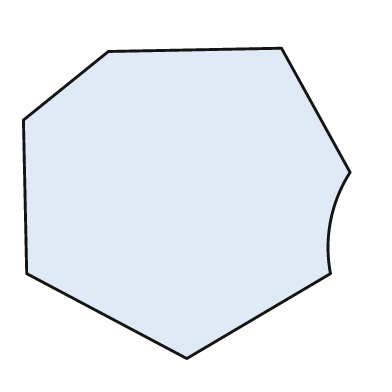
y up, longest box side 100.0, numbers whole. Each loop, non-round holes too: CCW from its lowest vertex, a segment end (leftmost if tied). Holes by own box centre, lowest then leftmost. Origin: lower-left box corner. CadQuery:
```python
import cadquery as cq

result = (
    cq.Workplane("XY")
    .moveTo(50.0, 0.0)
    .lineTo(94.0, 26.0)
    .threePointArc((94.0, 42.0), (100.0, 57.0))
    .lineTo(79.0, 95.0)
    .lineTo(26.0, 94.0)
    .lineTo(0.0, 73.0)
    .lineTo(1.0, 26.0)
    .close()
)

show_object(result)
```